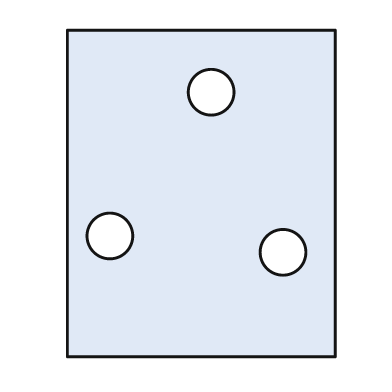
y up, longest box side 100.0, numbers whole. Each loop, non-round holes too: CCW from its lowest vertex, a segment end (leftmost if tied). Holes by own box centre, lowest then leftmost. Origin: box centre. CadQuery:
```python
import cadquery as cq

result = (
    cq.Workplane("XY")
    .moveTo(-41.0, -50.0)
    .lineTo(41.0, -50.0)
    .lineTo(41.0, 50.0)
    .lineTo(-41.0, 50.0)
    .close()
    .moveTo(25.0, -18.0)
    .circle(7.0)
    .moveTo(-28.0, -13.0)
    .circle(7.0)
    .moveTo(3.0, 31.0)
    .circle(7.0)
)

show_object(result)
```